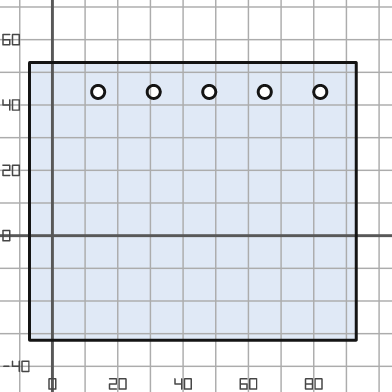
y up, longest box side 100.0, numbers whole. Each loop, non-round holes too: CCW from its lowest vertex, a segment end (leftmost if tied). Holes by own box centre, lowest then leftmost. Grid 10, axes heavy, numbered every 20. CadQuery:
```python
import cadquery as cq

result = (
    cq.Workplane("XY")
    .moveTo(-7.0, -32.0)
    .lineTo(93.0, -32.0)
    .lineTo(93.0, 53.0)
    .lineTo(-7.0, 53.0)
    .close()
    .moveTo(14.0, 44.0)
    .circle(2.0)
    .moveTo(31.0, 44.0)
    .circle(2.0)
    .moveTo(48.0, 44.0)
    .circle(2.0)
    .moveTo(65.0, 44.0)
    .circle(2.0)
    .moveTo(82.0, 44.0)
    .circle(2.0)
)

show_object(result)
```